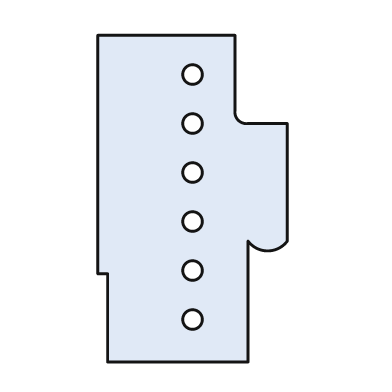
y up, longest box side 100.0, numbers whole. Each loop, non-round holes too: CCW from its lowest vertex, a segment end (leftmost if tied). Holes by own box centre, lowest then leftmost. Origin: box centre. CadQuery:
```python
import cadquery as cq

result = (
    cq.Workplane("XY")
    .moveTo(-26.0, -50.0)
    .lineTo(17.0, -50.0)
    .lineTo(17.0, -13.0)
    .threePointArc((23.0, -16.0), (29.0, -13.0))
    .lineTo(29.0, 23.0)
    .lineTo(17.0, 23.0)
    .threePointArc((14.0, 24.0), (13.0, 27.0))
    .lineTo(13.0, 50.0)
    .lineTo(-29.0, 50.0)
    .lineTo(-29.0, -23.0)
    .lineTo(-26.0, -23.0)
    .close()
    .moveTo(0.0, -37.0)
    .circle(3.0)
    .moveTo(0.0, -22.0)
    .circle(3.0)
    .moveTo(0.0, -7.0)
    .circle(3.0)
    .moveTo(0.0, 8.0)
    .circle(3.0)
    .moveTo(0.0, 23.0)
    .circle(3.0)
    .moveTo(0.0, 38.0)
    .circle(3.0)
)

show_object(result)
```